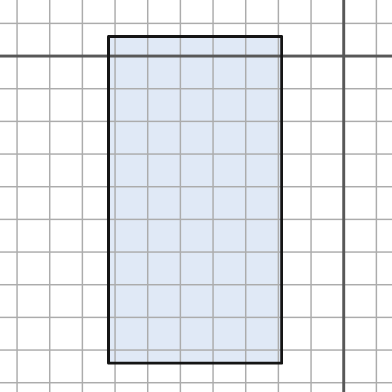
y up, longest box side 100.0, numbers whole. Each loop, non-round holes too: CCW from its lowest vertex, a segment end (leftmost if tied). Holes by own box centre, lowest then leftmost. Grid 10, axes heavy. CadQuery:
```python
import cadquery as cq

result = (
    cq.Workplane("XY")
    .moveTo(-72.0, -94.0)
    .lineTo(-19.0, -94.0)
    .lineTo(-19.0, 6.0)
    .lineTo(-72.0, 6.0)
    .close()
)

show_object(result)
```